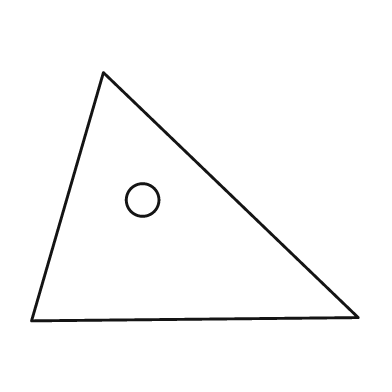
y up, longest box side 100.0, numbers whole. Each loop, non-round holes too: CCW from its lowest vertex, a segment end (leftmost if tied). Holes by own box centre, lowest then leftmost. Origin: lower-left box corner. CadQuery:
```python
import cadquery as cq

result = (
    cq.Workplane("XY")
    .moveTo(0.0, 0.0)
    .lineTo(100.0, 1.0)
    .lineTo(22.0, 76.0)
    .close()
    .moveTo(34.0, 37.0)
    .circle(5.0)
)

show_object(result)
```